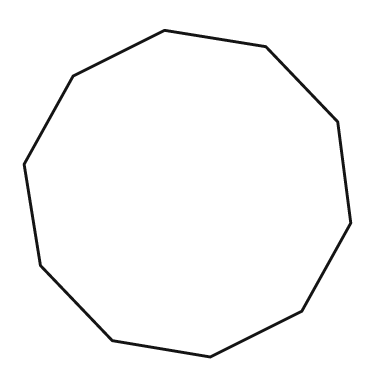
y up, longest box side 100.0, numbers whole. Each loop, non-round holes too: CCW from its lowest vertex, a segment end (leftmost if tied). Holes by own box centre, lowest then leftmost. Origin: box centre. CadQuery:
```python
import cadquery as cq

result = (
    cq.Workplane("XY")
    .moveTo(7.0, -50.0)
    .lineTo(35.0, -36.0)
    .lineTo(50.0, -9.0)
    .lineTo(46.0, 22.0)
    .lineTo(24.0, 45.0)
    .lineTo(-7.0, 50.0)
    .lineTo(-35.0, 36.0)
    .lineTo(-50.0, 9.0)
    .lineTo(-45.0, -22.0)
    .lineTo(-23.0, -45.0)
    .close()
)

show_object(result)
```